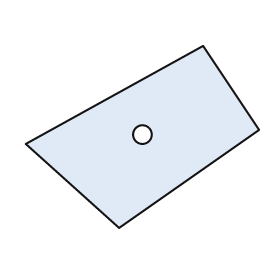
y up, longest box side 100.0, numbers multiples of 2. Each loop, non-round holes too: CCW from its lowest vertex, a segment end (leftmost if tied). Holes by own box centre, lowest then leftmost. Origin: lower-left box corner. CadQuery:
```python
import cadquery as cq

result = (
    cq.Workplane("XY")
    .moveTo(40.0, 0.0)
    .lineTo(100.0, 42.0)
    .lineTo(76.0, 78.0)
    .lineTo(0.0, 36.0)
    .close()
    .moveTo(50.0, 40.0)
    .circle(4.0)
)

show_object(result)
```